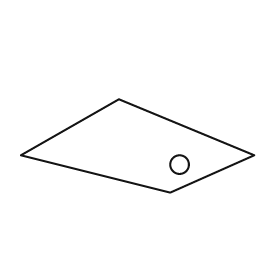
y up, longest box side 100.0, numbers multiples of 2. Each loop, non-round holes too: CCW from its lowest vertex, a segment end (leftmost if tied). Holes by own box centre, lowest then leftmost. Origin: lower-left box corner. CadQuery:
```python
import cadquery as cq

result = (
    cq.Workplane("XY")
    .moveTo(64.0, 0.0)
    .lineTo(100.0, 16.0)
    .lineTo(42.0, 40.0)
    .lineTo(0.0, 16.0)
    .close()
    .moveTo(68.0, 12.0)
    .circle(4.0)
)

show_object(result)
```